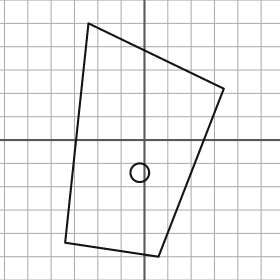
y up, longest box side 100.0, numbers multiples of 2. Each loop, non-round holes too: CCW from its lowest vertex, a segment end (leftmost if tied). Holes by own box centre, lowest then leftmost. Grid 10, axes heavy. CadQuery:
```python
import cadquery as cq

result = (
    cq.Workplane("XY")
    .moveTo(6.0, -50.0)
    .lineTo(34.0, 22.0)
    .lineTo(-24.0, 50.0)
    .lineTo(-34.0, -44.0)
    .close()
    .moveTo(-2.0, -14.0)
    .circle(4.0)
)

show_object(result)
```